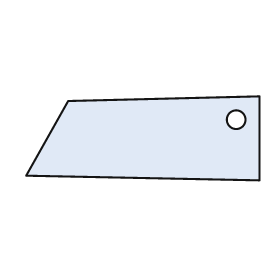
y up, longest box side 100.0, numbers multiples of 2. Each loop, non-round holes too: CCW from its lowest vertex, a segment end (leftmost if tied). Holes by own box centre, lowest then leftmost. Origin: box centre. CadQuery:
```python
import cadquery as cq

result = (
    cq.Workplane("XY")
    .moveTo(50.0, -18.0)
    .lineTo(50.0, 18.0)
    .lineTo(-32.0, 16.0)
    .lineTo(-50.0, -16.0)
    .close()
    .moveTo(40.0, 8.0)
    .circle(4.0)
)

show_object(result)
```